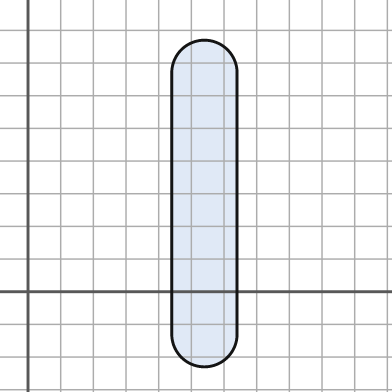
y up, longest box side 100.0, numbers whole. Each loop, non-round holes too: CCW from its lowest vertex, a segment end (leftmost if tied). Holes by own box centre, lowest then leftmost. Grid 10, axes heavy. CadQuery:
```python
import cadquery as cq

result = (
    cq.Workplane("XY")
    .moveTo(44.0, -13.0)
    .threePointArc((54.0, -23.0), (64.0, -13.0))
    .lineTo(64.0, 67.0)
    .threePointArc((54.0, 77.0), (44.0, 67.0))
    .close()
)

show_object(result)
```